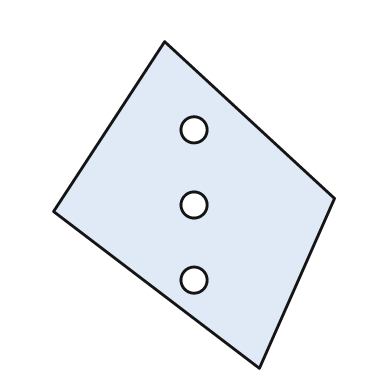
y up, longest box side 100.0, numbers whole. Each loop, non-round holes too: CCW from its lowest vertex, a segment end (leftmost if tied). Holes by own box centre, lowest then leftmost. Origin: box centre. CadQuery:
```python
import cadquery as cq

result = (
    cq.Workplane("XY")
    .moveTo(20.0, -50.0)
    .lineTo(43.0, 2.0)
    .lineTo(-9.0, 50.0)
    .lineTo(-43.0, -2.0)
    .close()
    .moveTo(0.0, -23.0)
    .circle(4.0)
    .moveTo(0.0, 0.0)
    .circle(4.0)
    .moveTo(0.0, 23.0)
    .circle(4.0)
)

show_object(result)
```